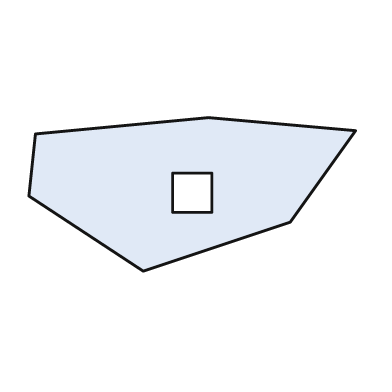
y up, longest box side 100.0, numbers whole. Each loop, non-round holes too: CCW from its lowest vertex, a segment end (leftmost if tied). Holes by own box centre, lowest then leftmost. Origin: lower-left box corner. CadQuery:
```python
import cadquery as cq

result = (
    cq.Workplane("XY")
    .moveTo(35.0, 0.0)
    .lineTo(80.0, 15.0)
    .lineTo(100.0, 43.0)
    .lineTo(55.0, 47.0)
    .lineTo(2.0, 42.0)
    .lineTo(0.0, 23.0)
    .close()
    .moveTo(44.0, 18.0)
    .lineTo(56.0, 18.0)
    .lineTo(56.0, 30.0)
    .lineTo(44.0, 30.0)
    .close()
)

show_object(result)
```